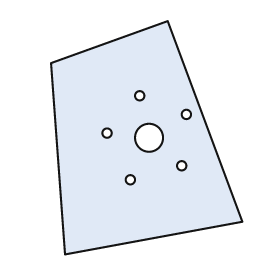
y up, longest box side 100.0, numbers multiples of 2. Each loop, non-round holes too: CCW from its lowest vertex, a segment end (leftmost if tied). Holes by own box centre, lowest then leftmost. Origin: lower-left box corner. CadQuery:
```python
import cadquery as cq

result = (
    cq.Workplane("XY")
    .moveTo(6.0, 0.0)
    .lineTo(82.0, 14.0)
    .lineTo(50.0, 100.0)
    .lineTo(0.0, 82.0)
    .close()
    .moveTo(34.0, 32.0)
    .circle(2.0)
    .moveTo(56.0, 38.0)
    .circle(2.0)
    .moveTo(42.0, 50.0)
    .circle(6.0)
    .moveTo(24.0, 52.0)
    .circle(2.0)
    .moveTo(58.0, 60.0)
    .circle(2.0)
    .moveTo(38.0, 68.0)
    .circle(2.0)
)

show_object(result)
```